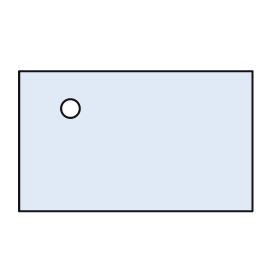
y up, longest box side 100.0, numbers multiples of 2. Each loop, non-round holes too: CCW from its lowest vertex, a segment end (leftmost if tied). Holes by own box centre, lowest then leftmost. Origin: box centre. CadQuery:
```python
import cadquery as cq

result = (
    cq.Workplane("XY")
    .moveTo(-50.0, -30.0)
    .lineTo(50.0, -30.0)
    .lineTo(50.0, 30.0)
    .lineTo(-50.0, 30.0)
    .close()
    .moveTo(-28.0, 14.0)
    .circle(4.0)
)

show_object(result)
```